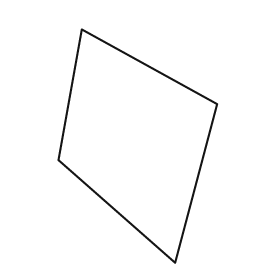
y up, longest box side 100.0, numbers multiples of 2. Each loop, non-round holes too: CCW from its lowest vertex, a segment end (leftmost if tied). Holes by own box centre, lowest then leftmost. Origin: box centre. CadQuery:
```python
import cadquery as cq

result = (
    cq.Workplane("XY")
    .moveTo(16.0, -50.0)
    .lineTo(34.0, 18.0)
    .lineTo(-24.0, 50.0)
    .lineTo(-34.0, -6.0)
    .close()
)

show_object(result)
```